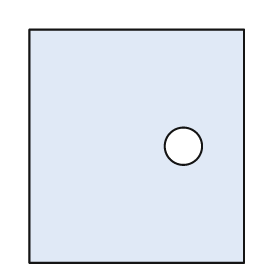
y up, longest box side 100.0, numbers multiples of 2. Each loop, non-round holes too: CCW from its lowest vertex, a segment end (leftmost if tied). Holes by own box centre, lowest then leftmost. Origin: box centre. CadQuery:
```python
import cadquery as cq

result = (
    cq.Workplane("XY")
    .moveTo(-46.0, -50.0)
    .lineTo(46.0, -50.0)
    .lineTo(46.0, 50.0)
    .lineTo(-46.0, 50.0)
    .close()
    .moveTo(20.0, 0.0)
    .circle(8.0)
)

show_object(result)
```